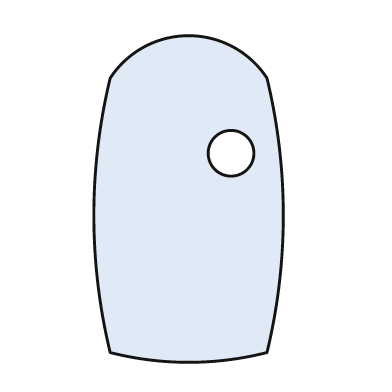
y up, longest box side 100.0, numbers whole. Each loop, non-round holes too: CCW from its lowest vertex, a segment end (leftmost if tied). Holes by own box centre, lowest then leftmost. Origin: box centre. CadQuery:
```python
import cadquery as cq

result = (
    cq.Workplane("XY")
    .moveTo(-24.0, -47.0)
    .threePointArc((0.0, -50.0), (24.0, -47.0))
    .threePointArc((29.0, -5.0), (24.0, 37.0))
    .threePointArc((0.0, 50.0), (-24.0, 37.0))
    .threePointArc((-29.0, -5.0), (-24.0, -47.0))
    .close()
    .moveTo(13.0, 14.0)
    .circle(7.0)
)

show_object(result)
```